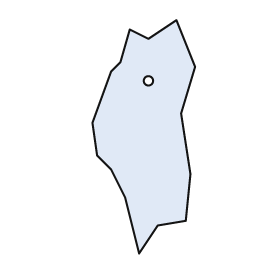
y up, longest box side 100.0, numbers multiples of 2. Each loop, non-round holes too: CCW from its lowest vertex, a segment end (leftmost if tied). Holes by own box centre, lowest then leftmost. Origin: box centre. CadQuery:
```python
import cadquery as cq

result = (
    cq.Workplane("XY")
    .moveTo(-2.0, -50.0)
    .lineTo(6.0, -38.0)
    .lineTo(18.0, -36.0)
    .lineTo(20.0, -16.0)
    .lineTo(16.0, 10.0)
    .lineTo(22.0, 30.0)
    .lineTo(14.0, 50.0)
    .lineTo(2.0, 42.0)
    .lineTo(-6.0, 46.0)
    .lineTo(-10.0, 32.0)
    .lineTo(-14.0, 28.0)
    .lineTo(-22.0, 6.0)
    .lineTo(-20.0, -8.0)
    .lineTo(-14.0, -14.0)
    .lineTo(-8.0, -26.0)
    .close()
    .moveTo(2.0, 24.0)
    .circle(2.0)
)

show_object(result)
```